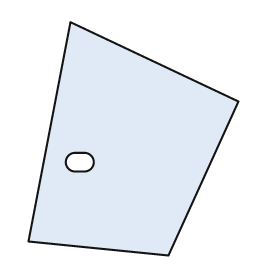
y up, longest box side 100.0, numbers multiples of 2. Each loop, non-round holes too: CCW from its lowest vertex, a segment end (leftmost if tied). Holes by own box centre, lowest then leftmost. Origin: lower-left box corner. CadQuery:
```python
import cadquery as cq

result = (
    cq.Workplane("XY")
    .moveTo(60.0, 0.0)
    .lineTo(90.0, 66.0)
    .lineTo(18.0, 100.0)
    .lineTo(0.0, 6.0)
    .close()
    .moveTo(20.0, 36.0)
    .lineTo(24.0, 36.0)
    .threePointArc((28.0, 40.0), (24.0, 44.0))
    .lineTo(20.0, 44.0)
    .threePointArc((16.0, 40.0), (20.0, 36.0))
    .close()
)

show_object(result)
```